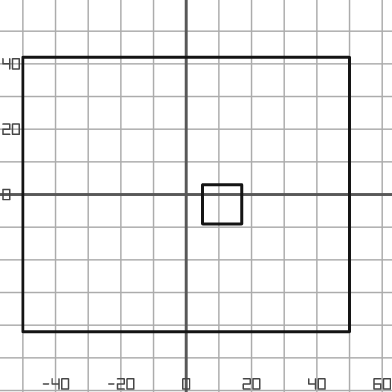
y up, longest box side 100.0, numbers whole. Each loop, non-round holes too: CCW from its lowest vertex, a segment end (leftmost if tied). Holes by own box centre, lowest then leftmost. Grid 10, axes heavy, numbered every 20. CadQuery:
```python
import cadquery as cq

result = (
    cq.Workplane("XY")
    .moveTo(-50.0, -42.0)
    .lineTo(50.0, -42.0)
    .lineTo(50.0, 42.0)
    .lineTo(-50.0, 42.0)
    .close()
    .moveTo(5.0, -9.0)
    .lineTo(17.0, -9.0)
    .lineTo(17.0, 3.0)
    .lineTo(5.0, 3.0)
    .close()
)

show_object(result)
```